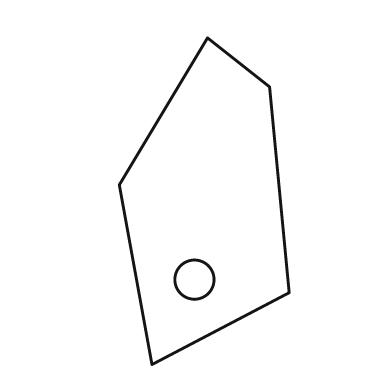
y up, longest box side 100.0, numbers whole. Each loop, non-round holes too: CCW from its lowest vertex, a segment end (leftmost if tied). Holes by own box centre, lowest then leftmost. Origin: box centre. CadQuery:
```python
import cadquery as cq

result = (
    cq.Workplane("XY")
    .moveTo(-16.0, -50.0)
    .lineTo(26.0, -28.0)
    .lineTo(20.0, 35.0)
    .lineTo(1.0, 50.0)
    .lineTo(-26.0, 5.0)
    .close()
    .moveTo(-3.0, -24.0)
    .circle(6.0)
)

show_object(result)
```